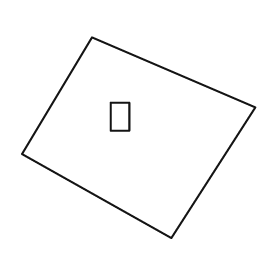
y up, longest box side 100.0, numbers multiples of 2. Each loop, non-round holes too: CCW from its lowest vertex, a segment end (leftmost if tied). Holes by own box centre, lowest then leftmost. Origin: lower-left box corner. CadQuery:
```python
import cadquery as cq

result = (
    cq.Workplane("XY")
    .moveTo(64.0, 0.0)
    .lineTo(100.0, 56.0)
    .lineTo(30.0, 86.0)
    .lineTo(0.0, 36.0)
    .close()
    .moveTo(38.0, 46.0)
    .lineTo(46.0, 46.0)
    .lineTo(46.0, 58.0)
    .lineTo(38.0, 58.0)
    .close()
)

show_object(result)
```